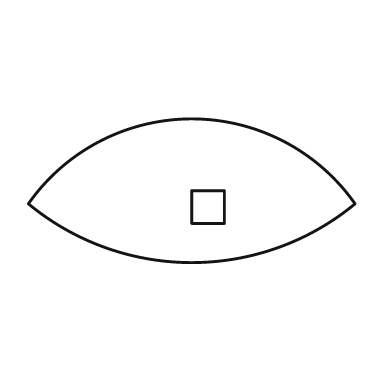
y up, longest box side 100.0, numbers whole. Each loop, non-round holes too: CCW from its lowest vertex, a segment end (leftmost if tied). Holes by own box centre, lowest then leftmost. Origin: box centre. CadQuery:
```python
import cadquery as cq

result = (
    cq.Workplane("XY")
    .moveTo(-50.0, -4.0)
    .threePointArc((0.0, -22.0), (50.0, -4.0))
    .threePointArc((0.0, 22.0), (-50.0, -4.0))
    .close()
    .moveTo(0.0, -10.0)
    .lineTo(10.0, -10.0)
    .lineTo(10.0, 0.0)
    .lineTo(0.0, 0.0)
    .close()
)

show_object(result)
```